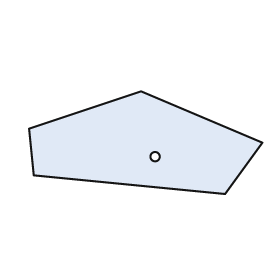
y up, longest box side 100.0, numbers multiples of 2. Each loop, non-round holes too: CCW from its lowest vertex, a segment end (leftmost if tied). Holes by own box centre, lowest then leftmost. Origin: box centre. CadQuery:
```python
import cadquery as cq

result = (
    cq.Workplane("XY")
    .moveTo(34.0, -22.0)
    .lineTo(50.0, 0.0)
    .lineTo(-2.0, 22.0)
    .lineTo(-50.0, 6.0)
    .lineTo(-48.0, -14.0)
    .close()
    .moveTo(4.0, -6.0)
    .circle(2.0)
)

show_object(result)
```